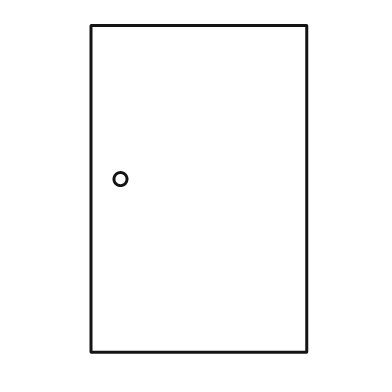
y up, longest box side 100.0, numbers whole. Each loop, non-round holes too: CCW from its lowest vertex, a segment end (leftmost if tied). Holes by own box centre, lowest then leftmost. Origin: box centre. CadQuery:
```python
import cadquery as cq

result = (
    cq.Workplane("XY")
    .moveTo(-33.0, -50.0)
    .lineTo(33.0, -50.0)
    .lineTo(33.0, 50.0)
    .lineTo(-33.0, 50.0)
    .close()
    .moveTo(-24.0, 3.0)
    .circle(2.0)
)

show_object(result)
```